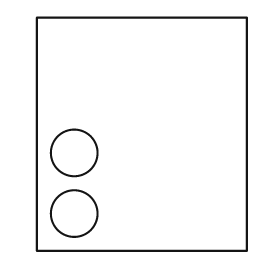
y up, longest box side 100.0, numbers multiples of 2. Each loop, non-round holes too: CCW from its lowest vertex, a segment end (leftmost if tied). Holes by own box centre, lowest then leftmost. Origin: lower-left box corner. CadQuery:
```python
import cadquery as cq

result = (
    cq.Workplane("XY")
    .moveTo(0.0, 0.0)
    .lineTo(90.0, 0.0)
    .lineTo(90.0, 100.0)
    .lineTo(0.0, 100.0)
    .close()
    .moveTo(16.0, 16.0)
    .circle(10.0)
    .moveTo(16.0, 42.0)
    .circle(10.0)
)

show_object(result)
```